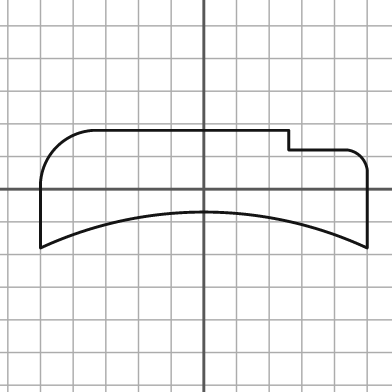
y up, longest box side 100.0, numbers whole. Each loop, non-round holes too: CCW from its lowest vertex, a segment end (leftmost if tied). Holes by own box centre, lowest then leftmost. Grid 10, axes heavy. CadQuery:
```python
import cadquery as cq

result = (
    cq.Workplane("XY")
    .moveTo(-50.0, -18.0)
    .threePointArc((0.0, -7.0), (50.0, -18.0))
    .lineTo(50.0, 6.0)
    .threePointArc((48.0, 10.0), (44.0, 12.0))
    .lineTo(26.0, 12.0)
    .lineTo(26.0, 18.0)
    .lineTo(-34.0, 18.0)
    .threePointArc((-45.0, 13.0), (-50.0, 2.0))
    .close()
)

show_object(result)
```